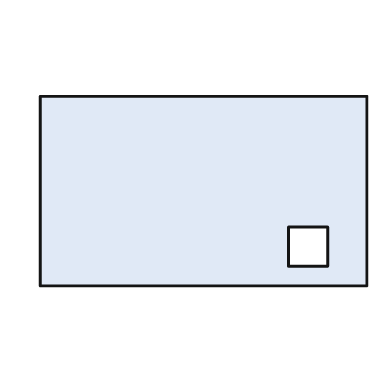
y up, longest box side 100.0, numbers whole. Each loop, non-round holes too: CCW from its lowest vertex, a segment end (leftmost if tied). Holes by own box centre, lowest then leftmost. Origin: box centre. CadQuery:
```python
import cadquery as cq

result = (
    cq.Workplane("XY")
    .moveTo(-50.0, -29.0)
    .lineTo(50.0, -29.0)
    .lineTo(50.0, 29.0)
    .lineTo(-50.0, 29.0)
    .close()
    .moveTo(26.0, -23.0)
    .lineTo(38.0, -23.0)
    .lineTo(38.0, -11.0)
    .lineTo(26.0, -11.0)
    .close()
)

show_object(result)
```